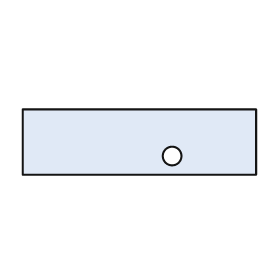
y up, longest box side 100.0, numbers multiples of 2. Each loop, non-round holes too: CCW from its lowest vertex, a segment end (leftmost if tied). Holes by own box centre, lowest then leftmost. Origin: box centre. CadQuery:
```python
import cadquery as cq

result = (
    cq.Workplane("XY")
    .moveTo(-50.0, -14.0)
    .lineTo(50.0, -14.0)
    .lineTo(50.0, 14.0)
    .lineTo(-50.0, 14.0)
    .close()
    .moveTo(14.0, -6.0)
    .circle(4.0)
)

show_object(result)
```